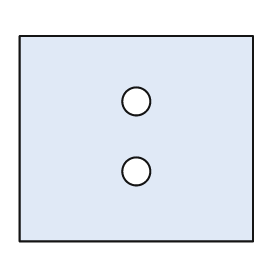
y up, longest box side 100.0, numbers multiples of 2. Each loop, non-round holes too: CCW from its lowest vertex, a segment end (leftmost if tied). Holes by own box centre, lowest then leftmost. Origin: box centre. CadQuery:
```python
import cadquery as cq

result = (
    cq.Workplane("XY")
    .moveTo(-50.0, -44.0)
    .lineTo(50.0, -44.0)
    .lineTo(50.0, 44.0)
    .lineTo(-50.0, 44.0)
    .close()
    .moveTo(0.0, -14.0)
    .circle(6.0)
    .moveTo(0.0, 16.0)
    .circle(6.0)
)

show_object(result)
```